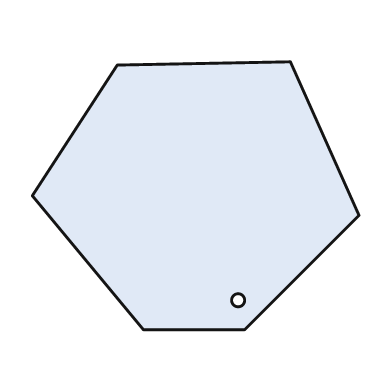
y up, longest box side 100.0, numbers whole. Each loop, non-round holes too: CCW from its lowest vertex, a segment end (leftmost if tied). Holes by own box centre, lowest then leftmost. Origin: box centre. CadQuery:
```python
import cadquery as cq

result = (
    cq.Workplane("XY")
    .moveTo(-16.0, -41.0)
    .lineTo(15.0, -41.0)
    .lineTo(50.0, -6.0)
    .lineTo(29.0, 41.0)
    .lineTo(-24.0, 40.0)
    .lineTo(-50.0, 0.0)
    .close()
    .moveTo(13.0, -32.0)
    .circle(2.0)
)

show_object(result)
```